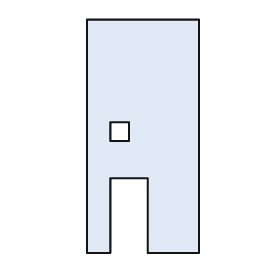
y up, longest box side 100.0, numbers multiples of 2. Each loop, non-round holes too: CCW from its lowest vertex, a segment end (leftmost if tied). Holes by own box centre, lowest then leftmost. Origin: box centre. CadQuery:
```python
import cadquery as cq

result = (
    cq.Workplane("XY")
    .moveTo(-24.0, -50.0)
    .lineTo(-14.0, -50.0)
    .lineTo(-14.0, -18.0)
    .lineTo(2.0, -18.0)
    .lineTo(2.0, -50.0)
    .lineTo(24.0, -50.0)
    .lineTo(24.0, 50.0)
    .lineTo(-24.0, 50.0)
    .close()
    .moveTo(-14.0, -2.0)
    .lineTo(-6.0, -2.0)
    .lineTo(-6.0, 6.0)
    .lineTo(-14.0, 6.0)
    .close()
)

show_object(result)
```